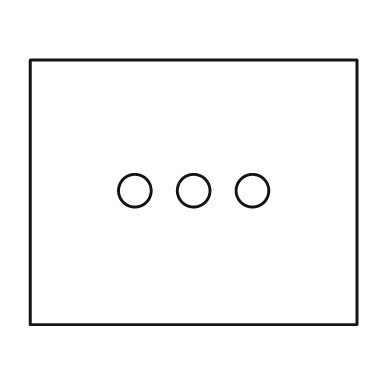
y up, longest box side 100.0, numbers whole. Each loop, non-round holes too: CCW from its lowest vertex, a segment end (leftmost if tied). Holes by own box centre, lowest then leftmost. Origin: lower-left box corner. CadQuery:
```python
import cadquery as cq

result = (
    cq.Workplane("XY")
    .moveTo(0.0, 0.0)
    .lineTo(100.0, 0.0)
    .lineTo(100.0, 81.0)
    .lineTo(0.0, 81.0)
    .close()
    .moveTo(32.0, 41.0)
    .circle(5.0)
    .moveTo(50.0, 41.0)
    .circle(5.0)
    .moveTo(68.0, 41.0)
    .circle(5.0)
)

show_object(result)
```